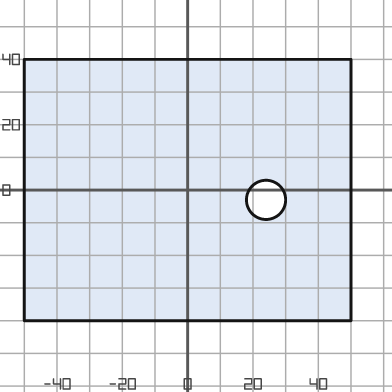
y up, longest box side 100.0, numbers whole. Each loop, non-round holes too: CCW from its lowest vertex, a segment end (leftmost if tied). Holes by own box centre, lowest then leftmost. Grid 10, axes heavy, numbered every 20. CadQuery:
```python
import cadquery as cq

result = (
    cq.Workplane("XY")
    .moveTo(-50.0, -40.0)
    .lineTo(50.0, -40.0)
    .lineTo(50.0, 40.0)
    .lineTo(-50.0, 40.0)
    .close()
    .moveTo(24.0, -3.0)
    .circle(6.0)
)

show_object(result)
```